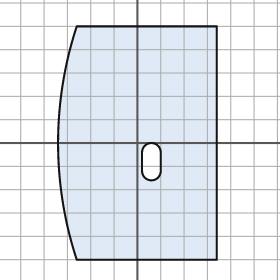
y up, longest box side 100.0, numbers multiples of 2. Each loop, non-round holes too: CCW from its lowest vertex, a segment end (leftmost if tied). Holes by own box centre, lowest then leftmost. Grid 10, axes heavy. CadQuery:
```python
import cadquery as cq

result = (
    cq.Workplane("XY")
    .moveTo(-26.0, -50.0)
    .lineTo(34.0, -50.0)
    .lineTo(34.0, 50.0)
    .lineTo(-26.0, 50.0)
    .threePointArc((-34.0, 0.0), (-26.0, -50.0))
    .close()
    .moveTo(2.0, -12.0)
    .threePointArc((6.0, -16.0), (10.0, -12.0))
    .lineTo(10.0, -4.0)
    .threePointArc((6.0, 0.0), (2.0, -4.0))
    .close()
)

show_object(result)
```